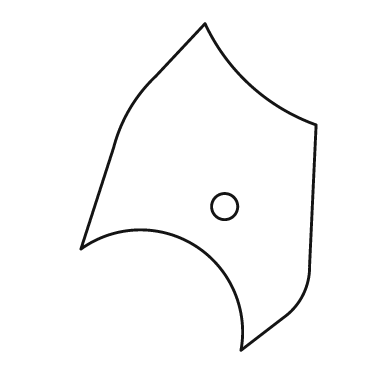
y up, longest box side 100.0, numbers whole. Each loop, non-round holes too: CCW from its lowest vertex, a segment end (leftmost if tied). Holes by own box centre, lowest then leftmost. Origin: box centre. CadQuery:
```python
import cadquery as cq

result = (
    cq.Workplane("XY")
    .moveTo(13.0, -50.0)
    .lineTo(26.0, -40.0)
    .threePointArc((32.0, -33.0), (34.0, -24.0))
    .lineTo(36.0, 19.0)
    .threePointArc((16.0, 31.0), (2.0, 50.0))
    .lineTo(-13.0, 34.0)
    .threePointArc((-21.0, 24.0), (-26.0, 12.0))
    .lineTo(-36.0, -19.0)
    .threePointArc((-1.0, -18.0), (13.0, -50.0))
    .close()
    .moveTo(8.0, -6.0)
    .circle(4.0)
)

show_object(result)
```